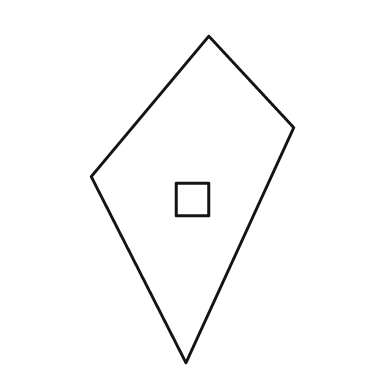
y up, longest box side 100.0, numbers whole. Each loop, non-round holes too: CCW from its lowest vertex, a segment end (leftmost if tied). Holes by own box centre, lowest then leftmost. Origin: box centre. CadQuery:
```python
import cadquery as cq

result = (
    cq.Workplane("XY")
    .moveTo(-2.0, -50.0)
    .lineTo(31.0, 22.0)
    .lineTo(5.0, 50.0)
    .lineTo(-31.0, 7.0)
    .close()
    .moveTo(-5.0, -5.0)
    .lineTo(5.0, -5.0)
    .lineTo(5.0, 5.0)
    .lineTo(-5.0, 5.0)
    .close()
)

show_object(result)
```